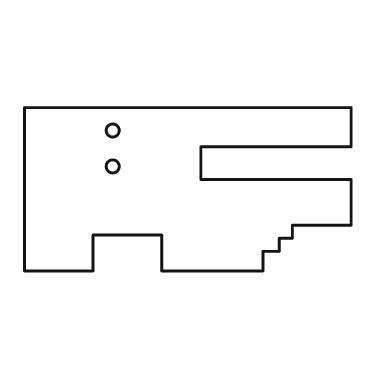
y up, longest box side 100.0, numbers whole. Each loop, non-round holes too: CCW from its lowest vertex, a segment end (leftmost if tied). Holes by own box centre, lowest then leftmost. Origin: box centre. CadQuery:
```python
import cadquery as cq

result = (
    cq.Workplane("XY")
    .moveTo(-50.0, -25.0)
    .lineTo(-29.0, -25.0)
    .lineTo(-29.0, -14.0)
    .lineTo(-8.0, -14.0)
    .lineTo(-8.0, -25.0)
    .lineTo(23.0, -25.0)
    .lineTo(23.0, -19.0)
    .lineTo(28.0, -19.0)
    .lineTo(28.0, -15.0)
    .lineTo(32.0, -15.0)
    .lineTo(32.0, -11.0)
    .lineTo(50.0, -11.0)
    .lineTo(50.0, 3.0)
    .lineTo(4.0, 3.0)
    .lineTo(4.0, 13.0)
    .lineTo(50.0, 13.0)
    .lineTo(50.0, 25.0)
    .lineTo(-50.0, 25.0)
    .close()
    .moveTo(-23.0, 7.0)
    .circle(2.0)
    .moveTo(-23.0, 18.0)
    .circle(2.0)
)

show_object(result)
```